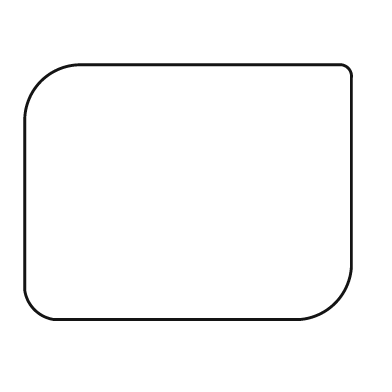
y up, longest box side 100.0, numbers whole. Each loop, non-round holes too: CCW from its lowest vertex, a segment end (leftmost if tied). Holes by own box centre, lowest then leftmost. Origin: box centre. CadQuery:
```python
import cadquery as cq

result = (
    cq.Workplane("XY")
    .moveTo(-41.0, -39.0)
    .lineTo(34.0, -39.0)
    .threePointArc((45.0, -34.0), (50.0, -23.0))
    .lineTo(50.0, 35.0)
    .threePointArc((49.0, 38.0), (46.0, 39.0))
    .lineTo(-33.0, 39.0)
    .threePointArc((-45.0, 34.0), (-50.0, 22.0))
    .lineTo(-50.0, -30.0)
    .threePointArc((-47.0, -36.0), (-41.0, -39.0))
    .close()
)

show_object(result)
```